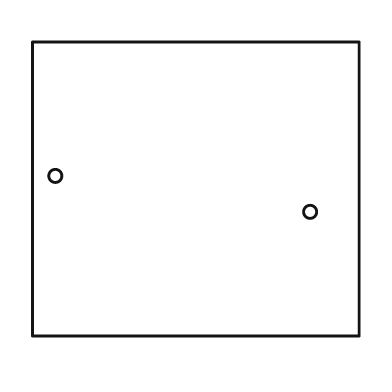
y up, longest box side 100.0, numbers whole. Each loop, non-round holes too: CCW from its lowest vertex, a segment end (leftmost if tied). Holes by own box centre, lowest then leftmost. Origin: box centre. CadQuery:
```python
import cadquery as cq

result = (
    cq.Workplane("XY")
    .moveTo(-50.0, -45.0)
    .lineTo(50.0, -45.0)
    .lineTo(50.0, 45.0)
    .lineTo(-50.0, 45.0)
    .close()
    .moveTo(35.0, -7.0)
    .circle(2.0)
    .moveTo(-43.0, 4.0)
    .circle(2.0)
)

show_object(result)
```